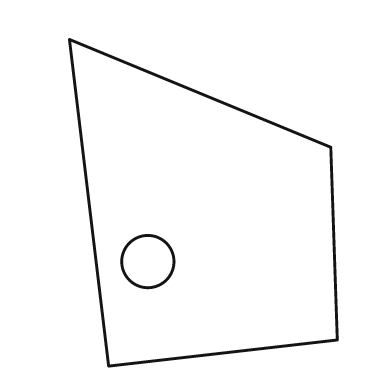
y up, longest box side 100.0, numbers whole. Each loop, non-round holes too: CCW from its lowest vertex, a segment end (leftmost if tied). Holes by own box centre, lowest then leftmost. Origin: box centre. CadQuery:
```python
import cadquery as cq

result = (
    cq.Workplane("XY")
    .moveTo(-29.0, -50.0)
    .lineTo(41.0, -42.0)
    .lineTo(39.0, 17.0)
    .lineTo(-41.0, 50.0)
    .close()
    .moveTo(-17.0, -18.0)
    .circle(8.0)
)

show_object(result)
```